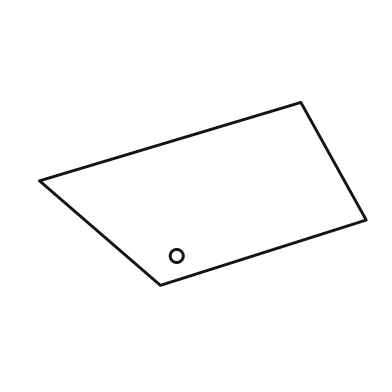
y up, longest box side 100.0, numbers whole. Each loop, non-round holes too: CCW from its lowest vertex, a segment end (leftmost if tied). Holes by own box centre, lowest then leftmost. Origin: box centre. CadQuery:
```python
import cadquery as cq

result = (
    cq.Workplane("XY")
    .moveTo(-13.0, -28.0)
    .lineTo(50.0, -8.0)
    .lineTo(30.0, 28.0)
    .lineTo(-50.0, 4.0)
    .close()
    .moveTo(-8.0, -19.0)
    .circle(2.0)
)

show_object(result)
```